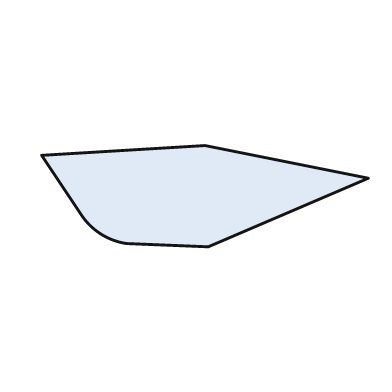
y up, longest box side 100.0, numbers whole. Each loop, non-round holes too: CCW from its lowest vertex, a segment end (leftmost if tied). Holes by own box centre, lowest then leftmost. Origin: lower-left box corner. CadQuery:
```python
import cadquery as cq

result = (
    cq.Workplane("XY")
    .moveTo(51.0, 0.0)
    .lineTo(100.0, 21.0)
    .lineTo(50.0, 31.0)
    .lineTo(0.0, 28.0)
    .lineTo(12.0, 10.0)
    .threePointArc((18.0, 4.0), (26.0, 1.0))
    .close()
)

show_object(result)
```